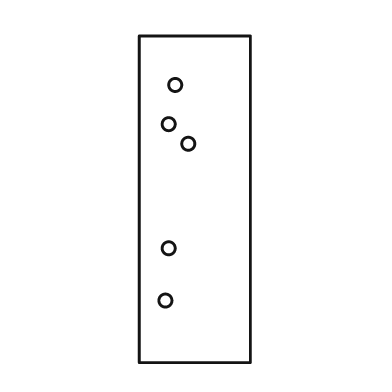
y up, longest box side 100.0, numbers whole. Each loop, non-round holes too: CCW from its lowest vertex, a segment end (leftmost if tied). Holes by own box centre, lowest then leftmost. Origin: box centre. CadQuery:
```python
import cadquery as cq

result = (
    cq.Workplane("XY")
    .moveTo(-17.0, -50.0)
    .lineTo(17.0, -50.0)
    .lineTo(17.0, 50.0)
    .lineTo(-17.0, 50.0)
    .close()
    .moveTo(-9.0, -31.0)
    .circle(2.0)
    .moveTo(-8.0, -15.0)
    .circle(2.0)
    .moveTo(-2.0, 17.0)
    .circle(2.0)
    .moveTo(-8.0, 23.0)
    .circle(2.0)
    .moveTo(-6.0, 35.0)
    .circle(2.0)
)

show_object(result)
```